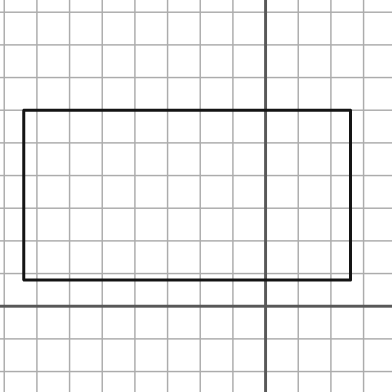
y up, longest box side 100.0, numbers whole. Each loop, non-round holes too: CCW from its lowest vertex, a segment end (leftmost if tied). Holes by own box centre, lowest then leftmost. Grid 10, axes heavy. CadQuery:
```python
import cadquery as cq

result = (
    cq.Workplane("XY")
    .moveTo(-74.0, 8.0)
    .lineTo(26.0, 8.0)
    .lineTo(26.0, 60.0)
    .lineTo(-74.0, 60.0)
    .close()
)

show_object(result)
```